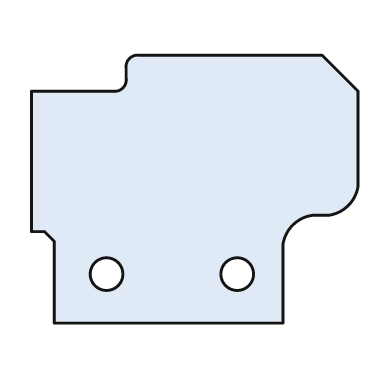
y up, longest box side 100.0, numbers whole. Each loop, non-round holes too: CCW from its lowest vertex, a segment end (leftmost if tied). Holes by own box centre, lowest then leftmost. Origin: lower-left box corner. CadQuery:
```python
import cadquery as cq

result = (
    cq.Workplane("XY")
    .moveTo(7.0, 0.0)
    .lineTo(77.0, 0.0)
    .lineTo(77.0, 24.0)
    .threePointArc((80.0, 30.0), (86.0, 33.0))
    .lineTo(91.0, 33.0)
    .threePointArc((97.0, 36.0), (100.0, 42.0))
    .lineTo(100.0, 71.0)
    .lineTo(89.0, 82.0)
    .lineTo(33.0, 82.0)
    .threePointArc((30.0, 81.0), (29.0, 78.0))
    .lineTo(29.0, 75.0)
    .threePointArc((28.0, 72.0), (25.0, 71.0))
    .lineTo(0.0, 71.0)
    .lineTo(0.0, 28.0)
    .lineTo(4.0, 28.0)
    .lineTo(7.0, 25.0)
    .close()
    .moveTo(23.0, 15.0)
    .circle(5.0)
    .moveTo(63.0, 15.0)
    .circle(5.0)
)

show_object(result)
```